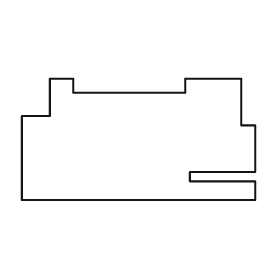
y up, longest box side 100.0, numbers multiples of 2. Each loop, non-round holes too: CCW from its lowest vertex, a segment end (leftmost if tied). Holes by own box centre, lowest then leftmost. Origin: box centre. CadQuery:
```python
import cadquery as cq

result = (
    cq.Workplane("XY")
    .moveTo(-50.0, -26.0)
    .lineTo(50.0, -26.0)
    .lineTo(50.0, -18.0)
    .lineTo(22.0, -18.0)
    .lineTo(22.0, -14.0)
    .lineTo(50.0, -14.0)
    .lineTo(50.0, 6.0)
    .lineTo(44.0, 6.0)
    .lineTo(44.0, 26.0)
    .lineTo(20.0, 26.0)
    .lineTo(20.0, 20.0)
    .lineTo(-28.0, 20.0)
    .lineTo(-28.0, 26.0)
    .lineTo(-38.0, 26.0)
    .lineTo(-38.0, 10.0)
    .lineTo(-50.0, 10.0)
    .close()
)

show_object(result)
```